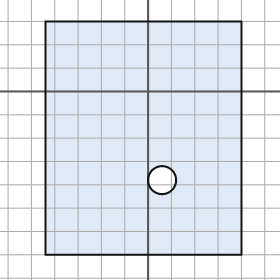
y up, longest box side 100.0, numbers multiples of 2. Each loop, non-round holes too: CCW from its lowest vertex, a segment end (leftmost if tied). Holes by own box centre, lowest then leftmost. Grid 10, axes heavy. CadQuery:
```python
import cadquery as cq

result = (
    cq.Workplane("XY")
    .moveTo(-44.0, -70.0)
    .lineTo(40.0, -70.0)
    .lineTo(40.0, 30.0)
    .lineTo(-44.0, 30.0)
    .close()
    .moveTo(6.0, -38.0)
    .circle(6.0)
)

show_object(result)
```